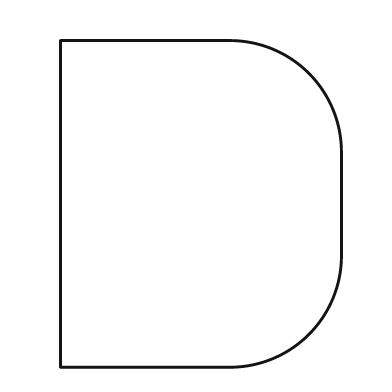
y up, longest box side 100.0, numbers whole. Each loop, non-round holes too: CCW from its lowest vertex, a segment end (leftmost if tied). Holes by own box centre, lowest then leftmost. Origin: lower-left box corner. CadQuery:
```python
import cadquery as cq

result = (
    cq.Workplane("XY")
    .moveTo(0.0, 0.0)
    .lineTo(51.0, 0.0)
    .threePointArc((76.0, 10.0), (86.0, 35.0))
    .lineTo(86.0, 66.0)
    .threePointArc((76.0, 90.0), (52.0, 100.0))
    .lineTo(0.0, 100.0)
    .close()
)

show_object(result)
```